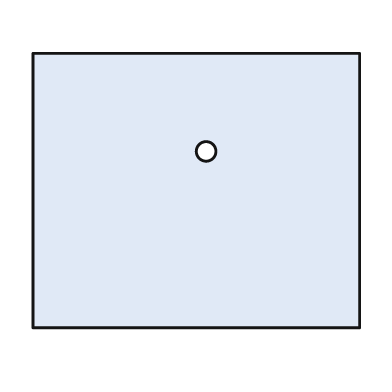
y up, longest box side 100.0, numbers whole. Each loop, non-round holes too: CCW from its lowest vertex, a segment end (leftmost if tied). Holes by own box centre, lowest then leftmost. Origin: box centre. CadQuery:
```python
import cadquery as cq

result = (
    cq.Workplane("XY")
    .moveTo(-50.0, -42.0)
    .lineTo(50.0, -42.0)
    .lineTo(50.0, 42.0)
    .lineTo(-50.0, 42.0)
    .close()
    .moveTo(3.0, 12.0)
    .circle(3.0)
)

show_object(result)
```